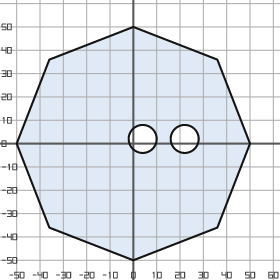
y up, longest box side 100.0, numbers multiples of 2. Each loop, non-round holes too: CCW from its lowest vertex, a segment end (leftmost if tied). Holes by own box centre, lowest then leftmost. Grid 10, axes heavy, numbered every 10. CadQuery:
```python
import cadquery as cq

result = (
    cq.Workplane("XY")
    .moveTo(0.0, -50.0)
    .lineTo(36.0, -36.0)
    .lineTo(50.0, 0.0)
    .lineTo(36.0, 36.0)
    .lineTo(0.0, 50.0)
    .lineTo(-36.0, 36.0)
    .lineTo(-50.0, 0.0)
    .lineTo(-36.0, -36.0)
    .close()
    .moveTo(4.0, 2.0)
    .circle(6.0)
    .moveTo(22.0, 2.0)
    .circle(6.0)
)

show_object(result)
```